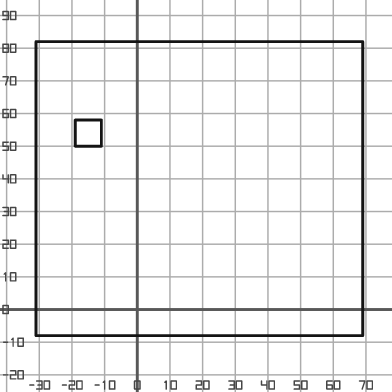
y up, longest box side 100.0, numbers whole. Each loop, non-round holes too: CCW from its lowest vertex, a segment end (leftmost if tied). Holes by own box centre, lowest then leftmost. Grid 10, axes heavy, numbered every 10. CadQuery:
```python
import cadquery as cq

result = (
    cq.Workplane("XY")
    .moveTo(-31.0, -8.0)
    .lineTo(69.0, -8.0)
    .lineTo(69.0, 82.0)
    .lineTo(-31.0, 82.0)
    .close()
    .moveTo(-19.0, 50.0)
    .lineTo(-11.0, 50.0)
    .lineTo(-11.0, 58.0)
    .lineTo(-19.0, 58.0)
    .close()
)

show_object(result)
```